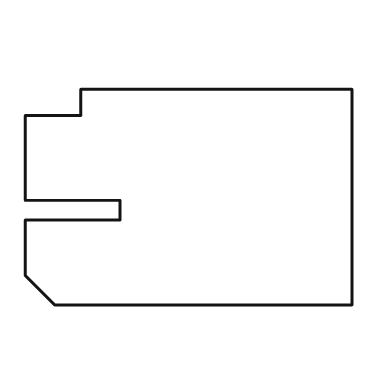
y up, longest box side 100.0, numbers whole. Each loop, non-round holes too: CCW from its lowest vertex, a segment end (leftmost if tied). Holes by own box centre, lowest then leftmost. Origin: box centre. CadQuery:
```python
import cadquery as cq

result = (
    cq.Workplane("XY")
    .moveTo(-41.0, -33.0)
    .lineTo(50.0, -33.0)
    .lineTo(50.0, 33.0)
    .lineTo(-33.0, 33.0)
    .lineTo(-33.0, 25.0)
    .lineTo(-50.0, 25.0)
    .lineTo(-50.0, -1.0)
    .lineTo(-21.0, -1.0)
    .lineTo(-21.0, -7.0)
    .lineTo(-50.0, -7.0)
    .lineTo(-50.0, -24.0)
    .close()
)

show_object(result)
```